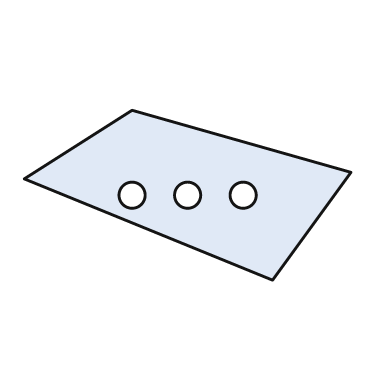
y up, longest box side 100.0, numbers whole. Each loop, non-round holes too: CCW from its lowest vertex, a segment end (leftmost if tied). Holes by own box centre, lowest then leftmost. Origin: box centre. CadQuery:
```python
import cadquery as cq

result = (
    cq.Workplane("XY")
    .moveTo(26.0, -26.0)
    .lineTo(50.0, 7.0)
    .lineTo(-17.0, 26.0)
    .lineTo(-50.0, 5.0)
    .close()
    .moveTo(-17.0, 0.0)
    .circle(4.0)
    .moveTo(0.0, 0.0)
    .circle(4.0)
    .moveTo(17.0, 0.0)
    .circle(4.0)
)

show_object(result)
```